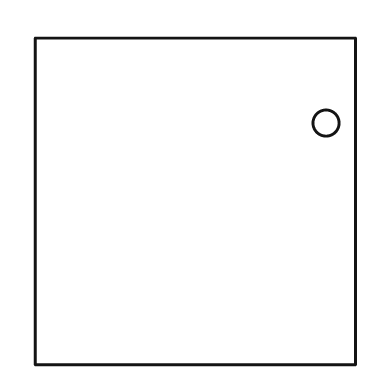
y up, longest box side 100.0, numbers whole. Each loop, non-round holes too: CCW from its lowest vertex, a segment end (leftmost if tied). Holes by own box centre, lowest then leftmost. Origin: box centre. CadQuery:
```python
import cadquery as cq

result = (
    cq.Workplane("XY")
    .moveTo(-49.0, -50.0)
    .lineTo(49.0, -50.0)
    .lineTo(49.0, 50.0)
    .lineTo(-49.0, 50.0)
    .close()
    .moveTo(40.0, 24.0)
    .circle(4.0)
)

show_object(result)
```